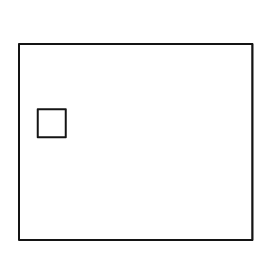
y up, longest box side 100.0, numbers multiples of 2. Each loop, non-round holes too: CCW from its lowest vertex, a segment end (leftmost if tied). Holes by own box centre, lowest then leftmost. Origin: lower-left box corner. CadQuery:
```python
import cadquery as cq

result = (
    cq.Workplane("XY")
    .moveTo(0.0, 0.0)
    .lineTo(100.0, 0.0)
    .lineTo(100.0, 84.0)
    .lineTo(0.0, 84.0)
    .close()
    .moveTo(8.0, 44.0)
    .lineTo(20.0, 44.0)
    .lineTo(20.0, 56.0)
    .lineTo(8.0, 56.0)
    .close()
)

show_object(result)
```